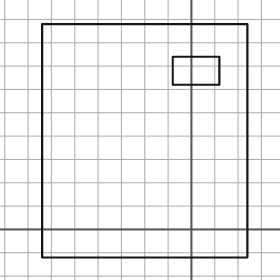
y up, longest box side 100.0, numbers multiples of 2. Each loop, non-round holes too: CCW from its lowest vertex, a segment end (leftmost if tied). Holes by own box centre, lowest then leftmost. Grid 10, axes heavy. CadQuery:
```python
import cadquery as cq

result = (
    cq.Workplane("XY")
    .moveTo(-64.0, -12.0)
    .lineTo(24.0, -12.0)
    .lineTo(24.0, 88.0)
    .lineTo(-64.0, 88.0)
    .close()
    .moveTo(-8.0, 62.0)
    .lineTo(12.0, 62.0)
    .lineTo(12.0, 74.0)
    .lineTo(-8.0, 74.0)
    .close()
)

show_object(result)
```